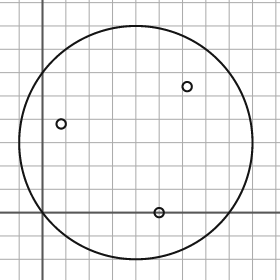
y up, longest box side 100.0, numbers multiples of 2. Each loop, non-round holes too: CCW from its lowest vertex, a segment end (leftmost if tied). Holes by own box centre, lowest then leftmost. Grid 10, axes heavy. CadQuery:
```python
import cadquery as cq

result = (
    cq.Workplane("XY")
    .moveTo(40.0, 30.0)
    .circle(50.0)
    .moveTo(50.0, 0.0)
    .circle(2.0)
    .moveTo(8.0, 38.0)
    .circle(2.0)
    .moveTo(62.0, 54.0)
    .circle(2.0)
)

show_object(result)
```